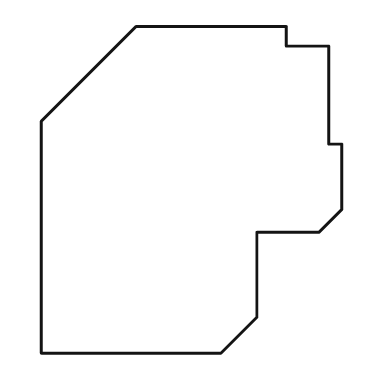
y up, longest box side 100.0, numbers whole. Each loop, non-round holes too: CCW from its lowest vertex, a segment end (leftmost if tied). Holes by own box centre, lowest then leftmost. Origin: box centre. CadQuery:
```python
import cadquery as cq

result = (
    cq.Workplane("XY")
    .moveTo(-46.0, -50.0)
    .lineTo(9.0, -50.0)
    .lineTo(20.0, -39.0)
    .lineTo(20.0, -13.0)
    .lineTo(39.0, -13.0)
    .lineTo(46.0, -6.0)
    .lineTo(46.0, 14.0)
    .lineTo(42.0, 14.0)
    .lineTo(42.0, 44.0)
    .lineTo(29.0, 44.0)
    .lineTo(29.0, 50.0)
    .lineTo(-17.0, 50.0)
    .lineTo(-46.0, 21.0)
    .close()
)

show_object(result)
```